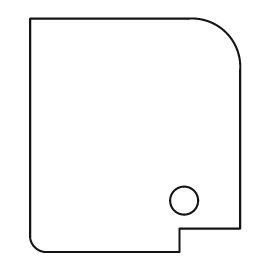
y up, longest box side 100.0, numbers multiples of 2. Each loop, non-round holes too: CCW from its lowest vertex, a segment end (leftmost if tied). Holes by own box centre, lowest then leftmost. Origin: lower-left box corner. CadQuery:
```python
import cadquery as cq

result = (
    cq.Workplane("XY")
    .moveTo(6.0, 0.0)
    .lineTo(64.0, 0.0)
    .lineTo(64.0, 10.0)
    .lineTo(90.0, 10.0)
    .lineTo(90.0, 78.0)
    .threePointArc((84.0, 94.0), (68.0, 100.0))
    .lineTo(0.0, 100.0)
    .lineTo(0.0, 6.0)
    .threePointArc((2.0, 2.0), (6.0, 0.0))
    .close()
    .moveTo(66.0, 22.0)
    .circle(6.0)
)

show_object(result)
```